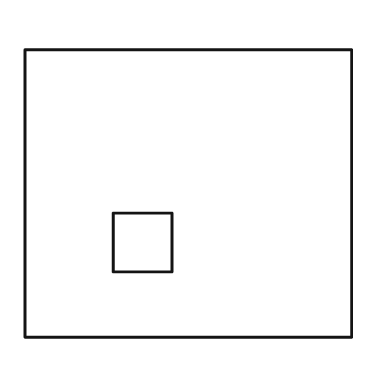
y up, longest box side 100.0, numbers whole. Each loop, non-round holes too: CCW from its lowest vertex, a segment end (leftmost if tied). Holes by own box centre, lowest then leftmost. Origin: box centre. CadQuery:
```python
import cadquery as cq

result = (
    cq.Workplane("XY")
    .moveTo(-50.0, -44.0)
    .lineTo(50.0, -44.0)
    .lineTo(50.0, 44.0)
    .lineTo(-50.0, 44.0)
    .close()
    .moveTo(-23.0, -24.0)
    .lineTo(-5.0, -24.0)
    .lineTo(-5.0, -6.0)
    .lineTo(-23.0, -6.0)
    .close()
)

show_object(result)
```